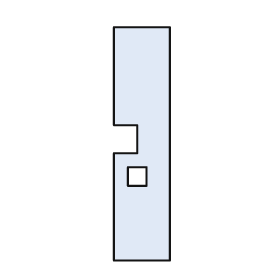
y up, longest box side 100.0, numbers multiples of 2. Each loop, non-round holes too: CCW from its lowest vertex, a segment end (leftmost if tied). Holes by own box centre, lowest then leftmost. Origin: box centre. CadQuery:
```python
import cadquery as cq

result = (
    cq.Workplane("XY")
    .moveTo(-12.0, -50.0)
    .lineTo(12.0, -50.0)
    .lineTo(12.0, 50.0)
    .lineTo(-12.0, 50.0)
    .lineTo(-12.0, 8.0)
    .lineTo(-2.0, 8.0)
    .lineTo(-2.0, -4.0)
    .lineTo(-12.0, -4.0)
    .close()
    .moveTo(-6.0, -18.0)
    .lineTo(2.0, -18.0)
    .lineTo(2.0, -10.0)
    .lineTo(-6.0, -10.0)
    .close()
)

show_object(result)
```